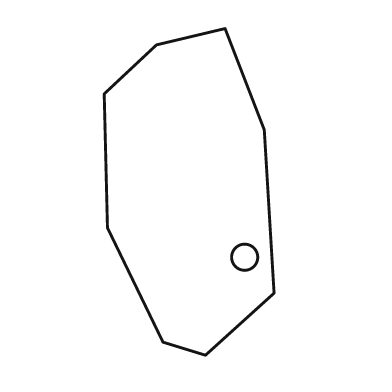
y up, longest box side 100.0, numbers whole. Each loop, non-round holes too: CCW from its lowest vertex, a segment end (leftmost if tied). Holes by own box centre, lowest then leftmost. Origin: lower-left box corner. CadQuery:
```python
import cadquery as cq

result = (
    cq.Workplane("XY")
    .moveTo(31.0, 0.0)
    .lineTo(52.0, 19.0)
    .lineTo(49.0, 69.0)
    .lineTo(37.0, 100.0)
    .lineTo(16.0, 95.0)
    .lineTo(0.0, 80.0)
    .lineTo(1.0, 39.0)
    .lineTo(18.0, 4.0)
    .close()
    .moveTo(43.0, 30.0)
    .circle(4.0)
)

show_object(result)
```